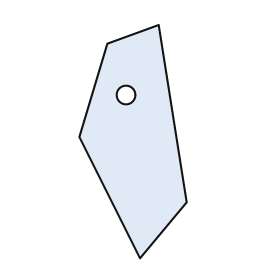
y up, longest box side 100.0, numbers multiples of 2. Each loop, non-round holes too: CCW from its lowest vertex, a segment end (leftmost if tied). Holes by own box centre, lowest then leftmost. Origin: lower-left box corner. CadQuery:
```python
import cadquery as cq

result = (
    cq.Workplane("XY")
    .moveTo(26.0, 0.0)
    .lineTo(46.0, 24.0)
    .lineTo(34.0, 100.0)
    .lineTo(12.0, 92.0)
    .lineTo(0.0, 52.0)
    .close()
    .moveTo(20.0, 70.0)
    .circle(4.0)
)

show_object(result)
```